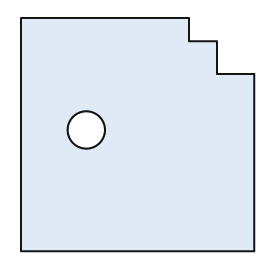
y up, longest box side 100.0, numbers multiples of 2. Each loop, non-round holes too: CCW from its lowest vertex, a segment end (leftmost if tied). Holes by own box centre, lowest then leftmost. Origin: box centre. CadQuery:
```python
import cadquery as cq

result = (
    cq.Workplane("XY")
    .moveTo(-50.0, -50.0)
    .lineTo(50.0, -50.0)
    .lineTo(50.0, 26.0)
    .lineTo(34.0, 26.0)
    .lineTo(34.0, 40.0)
    .lineTo(22.0, 40.0)
    .lineTo(22.0, 50.0)
    .lineTo(-50.0, 50.0)
    .close()
    .moveTo(-22.0, 2.0)
    .circle(8.0)
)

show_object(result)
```